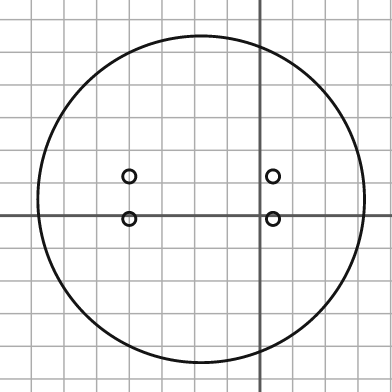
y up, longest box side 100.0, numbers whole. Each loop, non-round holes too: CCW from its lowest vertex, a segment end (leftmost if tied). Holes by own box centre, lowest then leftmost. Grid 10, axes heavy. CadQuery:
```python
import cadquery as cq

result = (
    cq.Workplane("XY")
    .moveTo(-18.0, 5.0)
    .circle(50.0)
    .moveTo(-40.0, -1.0)
    .circle(2.0)
    .moveTo(4.0, -1.0)
    .circle(2.0)
    .moveTo(-40.0, 12.0)
    .circle(2.0)
    .moveTo(4.0, 12.0)
    .circle(2.0)
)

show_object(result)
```